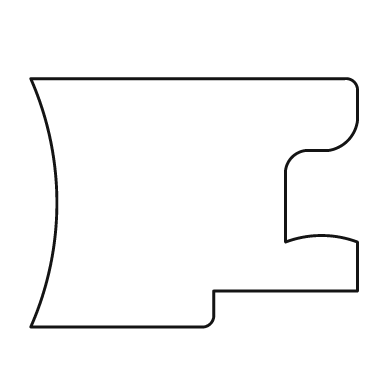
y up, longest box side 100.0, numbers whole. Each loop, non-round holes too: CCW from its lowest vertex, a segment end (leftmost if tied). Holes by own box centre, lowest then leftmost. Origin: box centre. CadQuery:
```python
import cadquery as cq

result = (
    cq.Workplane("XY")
    .moveTo(-50.0, -38.0)
    .lineTo(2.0, -38.0)
    .threePointArc((5.0, -37.0), (6.0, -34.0))
    .lineTo(6.0, -27.0)
    .lineTo(50.0, -27.0)
    .lineTo(50.0, -12.0)
    .threePointArc((39.0, -10.0), (28.0, -12.0))
    .lineTo(28.0, 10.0)
    .threePointArc((30.0, 14.0), (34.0, 16.0))
    .lineTo(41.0, 16.0)
    .threePointArc((47.0, 19.0), (50.0, 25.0))
    .lineTo(50.0, 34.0)
    .threePointArc((49.0, 37.0), (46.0, 38.0))
    .lineTo(-50.0, 38.0)
    .threePointArc((-42.0, 0.0), (-50.0, -38.0))
    .close()
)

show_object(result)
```